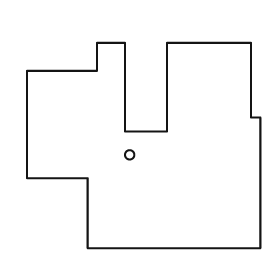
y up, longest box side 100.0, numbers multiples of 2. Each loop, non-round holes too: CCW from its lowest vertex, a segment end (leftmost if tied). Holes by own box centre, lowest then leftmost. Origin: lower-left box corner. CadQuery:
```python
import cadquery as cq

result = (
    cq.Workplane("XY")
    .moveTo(26.0, 0.0)
    .lineTo(100.0, 0.0)
    .lineTo(100.0, 56.0)
    .lineTo(96.0, 56.0)
    .lineTo(96.0, 88.0)
    .lineTo(60.0, 88.0)
    .lineTo(60.0, 50.0)
    .lineTo(42.0, 50.0)
    .lineTo(42.0, 88.0)
    .lineTo(30.0, 88.0)
    .lineTo(30.0, 76.0)
    .lineTo(0.0, 76.0)
    .lineTo(0.0, 30.0)
    .lineTo(26.0, 30.0)
    .close()
    .moveTo(44.0, 40.0)
    .circle(2.0)
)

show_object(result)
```